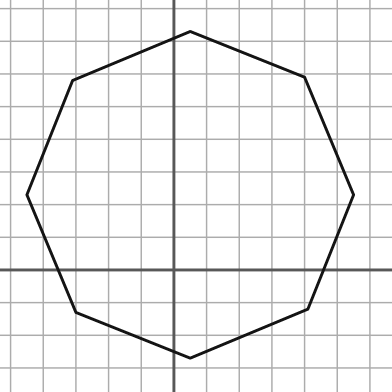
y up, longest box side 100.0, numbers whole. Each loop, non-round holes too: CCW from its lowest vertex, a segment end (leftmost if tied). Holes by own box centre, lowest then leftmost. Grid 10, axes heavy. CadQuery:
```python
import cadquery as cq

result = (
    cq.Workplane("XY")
    .moveTo(5.0, -27.0)
    .lineTo(41.0, -12.0)
    .lineTo(55.0, 23.0)
    .lineTo(40.0, 59.0)
    .lineTo(5.0, 73.0)
    .lineTo(-31.0, 58.0)
    .lineTo(-45.0, 23.0)
    .lineTo(-30.0, -13.0)
    .close()
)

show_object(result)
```